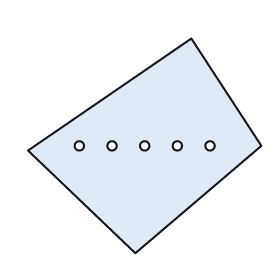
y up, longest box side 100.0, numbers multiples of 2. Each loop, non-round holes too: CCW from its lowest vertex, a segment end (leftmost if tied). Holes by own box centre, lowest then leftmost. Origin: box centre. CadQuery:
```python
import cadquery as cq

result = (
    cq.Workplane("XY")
    .moveTo(-4.0, -46.0)
    .lineTo(50.0, 0.0)
    .lineTo(20.0, 46.0)
    .lineTo(-50.0, -2.0)
    .close()
    .moveTo(-28.0, 0.0)
    .circle(2.0)
    .moveTo(-14.0, 0.0)
    .circle(2.0)
    .moveTo(0.0, 0.0)
    .circle(2.0)
    .moveTo(14.0, 0.0)
    .circle(2.0)
    .moveTo(28.0, 0.0)
    .circle(2.0)
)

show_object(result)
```